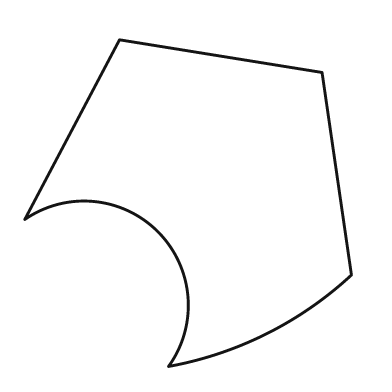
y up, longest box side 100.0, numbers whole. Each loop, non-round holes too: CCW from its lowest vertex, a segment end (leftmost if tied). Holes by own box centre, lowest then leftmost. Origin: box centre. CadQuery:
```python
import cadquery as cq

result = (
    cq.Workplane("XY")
    .moveTo(-6.0, -50.0)
    .threePointArc((24.0, -40.0), (50.0, -22.0))
    .lineTo(41.0, 40.0)
    .lineTo(-21.0, 50.0)
    .lineTo(-50.0, -5.0)
    .threePointArc((-9.0, -9.0), (-6.0, -50.0))
    .close()
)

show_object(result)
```